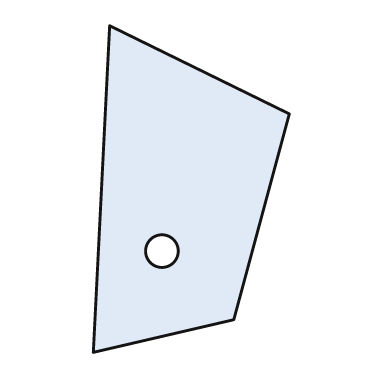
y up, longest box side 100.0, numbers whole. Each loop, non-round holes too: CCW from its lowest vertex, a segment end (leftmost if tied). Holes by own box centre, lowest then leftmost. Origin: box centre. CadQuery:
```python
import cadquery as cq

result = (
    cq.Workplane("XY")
    .moveTo(-30.0, -50.0)
    .lineTo(13.0, -40.0)
    .lineTo(30.0, 23.0)
    .lineTo(-25.0, 50.0)
    .close()
    .moveTo(-9.0, -19.0)
    .circle(5.0)
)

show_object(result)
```